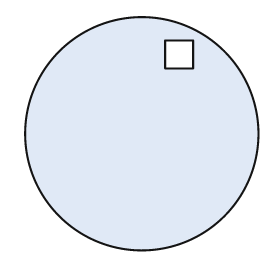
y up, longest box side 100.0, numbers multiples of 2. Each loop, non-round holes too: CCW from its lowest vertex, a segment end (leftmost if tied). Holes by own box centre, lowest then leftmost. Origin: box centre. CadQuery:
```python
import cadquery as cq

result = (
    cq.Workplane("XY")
    .moveTo(0.0, 0.0)
    .circle(50.0)
    .moveTo(10.0, 28.0)
    .lineTo(22.0, 28.0)
    .lineTo(22.0, 40.0)
    .lineTo(10.0, 40.0)
    .close()
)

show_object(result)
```